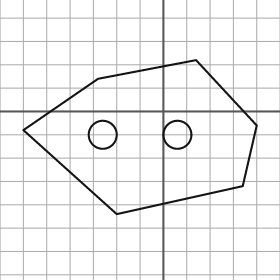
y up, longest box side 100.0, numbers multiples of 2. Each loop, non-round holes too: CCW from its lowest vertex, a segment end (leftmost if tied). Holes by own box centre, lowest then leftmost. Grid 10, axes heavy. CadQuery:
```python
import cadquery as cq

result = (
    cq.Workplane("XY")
    .moveTo(-20.0, -44.0)
    .lineTo(34.0, -32.0)
    .lineTo(40.0, -6.0)
    .lineTo(14.0, 22.0)
    .lineTo(-28.0, 14.0)
    .lineTo(-60.0, -8.0)
    .close()
    .moveTo(-26.0, -10.0)
    .circle(6.0)
    .moveTo(6.0, -10.0)
    .circle(6.0)
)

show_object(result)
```